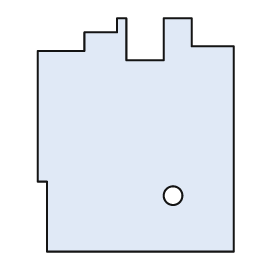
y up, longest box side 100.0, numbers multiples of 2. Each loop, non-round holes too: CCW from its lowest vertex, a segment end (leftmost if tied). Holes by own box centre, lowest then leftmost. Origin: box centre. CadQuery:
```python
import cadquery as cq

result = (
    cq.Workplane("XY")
    .moveTo(-38.0, -50.0)
    .lineTo(42.0, -50.0)
    .lineTo(42.0, 38.0)
    .lineTo(24.0, 38.0)
    .lineTo(24.0, 50.0)
    .lineTo(12.0, 50.0)
    .lineTo(12.0, 32.0)
    .lineTo(-4.0, 32.0)
    .lineTo(-4.0, 50.0)
    .lineTo(-8.0, 50.0)
    .lineTo(-8.0, 44.0)
    .lineTo(-22.0, 44.0)
    .lineTo(-22.0, 36.0)
    .lineTo(-42.0, 36.0)
    .lineTo(-42.0, -20.0)
    .lineTo(-38.0, -20.0)
    .close()
    .moveTo(16.0, -26.0)
    .circle(4.0)
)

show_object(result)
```